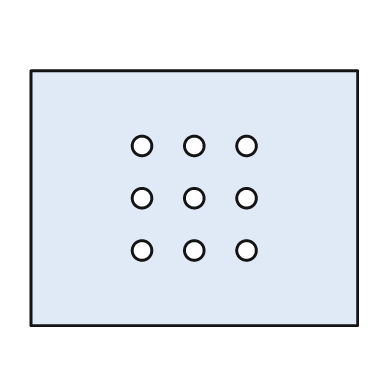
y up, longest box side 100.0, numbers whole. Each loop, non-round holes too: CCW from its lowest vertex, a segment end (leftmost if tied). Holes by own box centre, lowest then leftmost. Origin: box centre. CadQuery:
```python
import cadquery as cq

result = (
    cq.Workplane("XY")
    .moveTo(-50.0, -39.0)
    .lineTo(50.0, -39.0)
    .lineTo(50.0, 39.0)
    .lineTo(-50.0, 39.0)
    .close()
    .moveTo(-16.0, -16.0)
    .circle(3.0)
    .moveTo(0.0, -16.0)
    .circle(3.0)
    .moveTo(16.0, -16.0)
    .circle(3.0)
    .moveTo(-16.0, 0.0)
    .circle(3.0)
    .moveTo(0.0, 0.0)
    .circle(3.0)
    .moveTo(16.0, 0.0)
    .circle(3.0)
    .moveTo(-16.0, 16.0)
    .circle(3.0)
    .moveTo(0.0, 16.0)
    .circle(3.0)
    .moveTo(16.0, 16.0)
    .circle(3.0)
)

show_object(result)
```